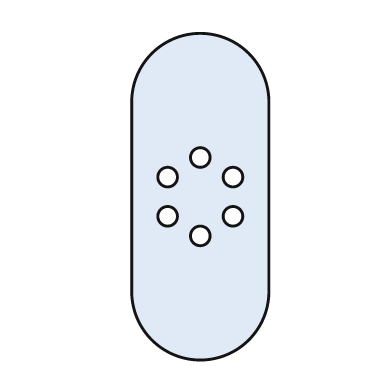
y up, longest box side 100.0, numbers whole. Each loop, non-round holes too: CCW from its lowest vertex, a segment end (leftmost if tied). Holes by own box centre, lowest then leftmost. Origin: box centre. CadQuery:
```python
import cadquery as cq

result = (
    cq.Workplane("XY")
    .moveTo(-21.0, -29.0)
    .threePointArc((0.0, -50.0), (21.0, -29.0))
    .lineTo(21.0, 29.0)
    .threePointArc((0.0, 50.0), (-21.0, 29.0))
    .close()
    .moveTo(0.0, -12.0)
    .circle(3.0)
    .moveTo(-10.0, -6.0)
    .circle(3.0)
    .moveTo(10.0, -6.0)
    .circle(3.0)
    .moveTo(-10.0, 6.0)
    .circle(3.0)
    .moveTo(10.0, 6.0)
    .circle(3.0)
    .moveTo(0.0, 12.0)
    .circle(3.0)
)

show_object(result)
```